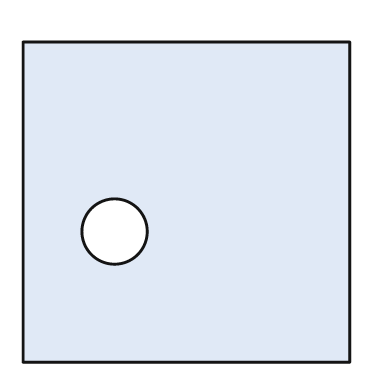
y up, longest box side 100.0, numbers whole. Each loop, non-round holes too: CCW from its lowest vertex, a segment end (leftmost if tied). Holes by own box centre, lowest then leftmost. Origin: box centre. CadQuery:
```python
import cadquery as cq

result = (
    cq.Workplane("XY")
    .moveTo(-50.0, -49.0)
    .lineTo(50.0, -49.0)
    .lineTo(50.0, 49.0)
    .lineTo(-50.0, 49.0)
    .close()
    .moveTo(-22.0, -9.0)
    .circle(10.0)
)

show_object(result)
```